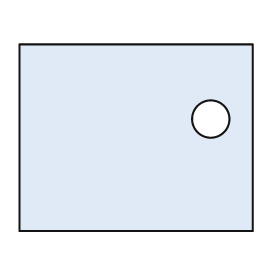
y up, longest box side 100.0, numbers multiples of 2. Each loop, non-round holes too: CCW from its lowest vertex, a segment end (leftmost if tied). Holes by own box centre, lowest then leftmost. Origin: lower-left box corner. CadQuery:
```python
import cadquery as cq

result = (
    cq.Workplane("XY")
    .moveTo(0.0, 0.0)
    .lineTo(100.0, 0.0)
    .lineTo(100.0, 80.0)
    .lineTo(0.0, 80.0)
    .close()
    .moveTo(82.0, 48.0)
    .circle(8.0)
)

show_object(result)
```